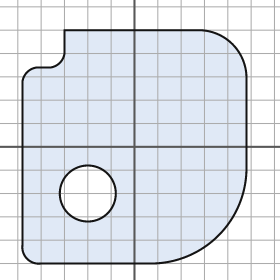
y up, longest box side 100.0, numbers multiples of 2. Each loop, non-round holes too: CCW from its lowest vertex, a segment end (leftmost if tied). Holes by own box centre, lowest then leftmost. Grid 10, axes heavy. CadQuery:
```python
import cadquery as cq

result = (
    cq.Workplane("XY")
    .moveTo(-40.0, -50.0)
    .lineTo(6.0, -50.0)
    .threePointArc((36.0, -38.0), (48.0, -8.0))
    .lineTo(48.0, 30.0)
    .threePointArc((42.0, 44.0), (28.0, 50.0))
    .lineTo(-30.0, 50.0)
    .lineTo(-30.0, 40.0)
    .threePointArc((-32.0, 36.0), (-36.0, 34.0))
    .lineTo(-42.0, 34.0)
    .threePointArc((-46.0, 32.0), (-48.0, 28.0))
    .lineTo(-48.0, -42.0)
    .threePointArc((-46.0, -48.0), (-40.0, -50.0))
    .close()
    .moveTo(-20.0, -20.0)
    .circle(12.0)
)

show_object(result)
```